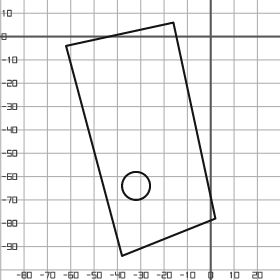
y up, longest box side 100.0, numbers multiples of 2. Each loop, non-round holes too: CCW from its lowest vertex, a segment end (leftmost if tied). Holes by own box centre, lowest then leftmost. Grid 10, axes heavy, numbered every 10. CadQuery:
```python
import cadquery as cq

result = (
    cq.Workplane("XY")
    .moveTo(-38.0, -94.0)
    .lineTo(2.0, -78.0)
    .lineTo(-16.0, 6.0)
    .lineTo(-62.0, -4.0)
    .close()
    .moveTo(-32.0, -64.0)
    .circle(6.0)
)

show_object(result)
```